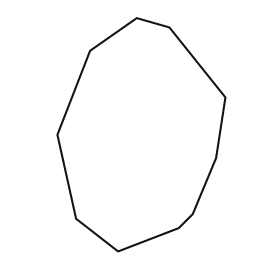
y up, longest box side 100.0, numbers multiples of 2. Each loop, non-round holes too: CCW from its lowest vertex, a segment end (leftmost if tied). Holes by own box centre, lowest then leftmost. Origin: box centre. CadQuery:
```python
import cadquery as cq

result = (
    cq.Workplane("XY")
    .moveTo(-10.0, -50.0)
    .lineTo(16.0, -40.0)
    .lineTo(22.0, -34.0)
    .lineTo(32.0, -10.0)
    .lineTo(36.0, 16.0)
    .lineTo(12.0, 46.0)
    .lineTo(-2.0, 50.0)
    .lineTo(-22.0, 36.0)
    .lineTo(-36.0, 0.0)
    .lineTo(-28.0, -36.0)
    .close()
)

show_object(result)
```